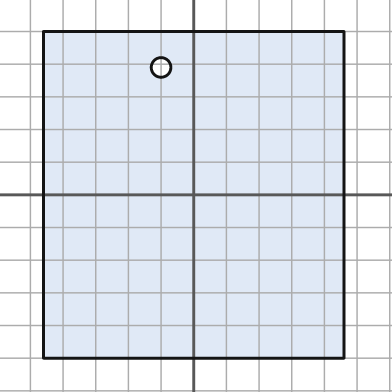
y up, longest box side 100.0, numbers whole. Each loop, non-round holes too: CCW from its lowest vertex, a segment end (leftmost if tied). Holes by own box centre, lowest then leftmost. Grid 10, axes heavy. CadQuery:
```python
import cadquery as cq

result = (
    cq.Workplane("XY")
    .moveTo(-46.0, -50.0)
    .lineTo(46.0, -50.0)
    .lineTo(46.0, 50.0)
    .lineTo(-46.0, 50.0)
    .close()
    .moveTo(-10.0, 39.0)
    .circle(3.0)
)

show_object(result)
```